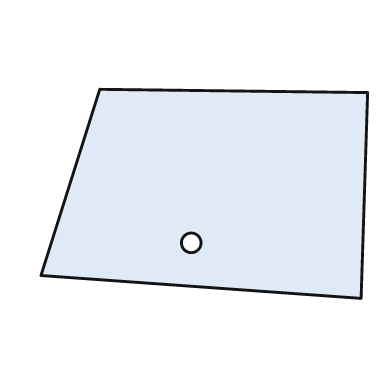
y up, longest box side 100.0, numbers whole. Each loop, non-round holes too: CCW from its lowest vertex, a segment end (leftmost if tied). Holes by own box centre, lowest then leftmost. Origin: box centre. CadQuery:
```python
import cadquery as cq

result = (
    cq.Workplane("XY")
    .moveTo(48.0, -32.0)
    .lineTo(50.0, 31.0)
    .lineTo(-32.0, 32.0)
    .lineTo(-50.0, -25.0)
    .close()
    .moveTo(-4.0, -15.0)
    .circle(3.0)
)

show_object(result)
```